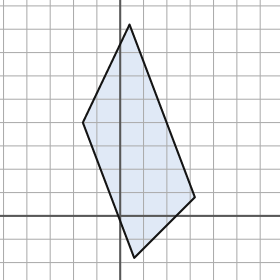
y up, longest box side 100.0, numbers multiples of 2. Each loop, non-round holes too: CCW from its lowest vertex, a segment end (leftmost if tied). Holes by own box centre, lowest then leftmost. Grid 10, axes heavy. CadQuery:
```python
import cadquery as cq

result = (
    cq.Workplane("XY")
    .moveTo(6.0, -18.0)
    .lineTo(32.0, 8.0)
    .lineTo(4.0, 82.0)
    .lineTo(-16.0, 40.0)
    .close()
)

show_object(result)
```